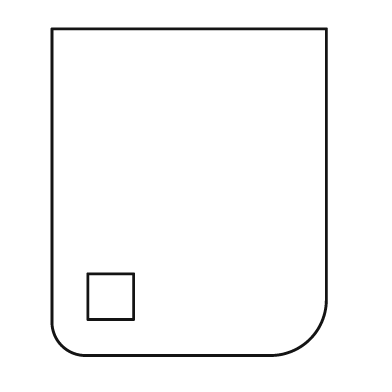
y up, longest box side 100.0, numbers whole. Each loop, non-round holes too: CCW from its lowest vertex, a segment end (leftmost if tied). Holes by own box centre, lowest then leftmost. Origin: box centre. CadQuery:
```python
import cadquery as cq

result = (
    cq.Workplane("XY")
    .moveTo(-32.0, -50.0)
    .lineTo(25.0, -50.0)
    .threePointArc((37.0, -45.0), (42.0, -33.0))
    .lineTo(42.0, 50.0)
    .lineTo(-42.0, 50.0)
    .lineTo(-42.0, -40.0)
    .threePointArc((-39.0, -47.0), (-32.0, -50.0))
    .close()
    .moveTo(-31.0, -39.0)
    .lineTo(-17.0, -39.0)
    .lineTo(-17.0, -25.0)
    .lineTo(-31.0, -25.0)
    .close()
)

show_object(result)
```